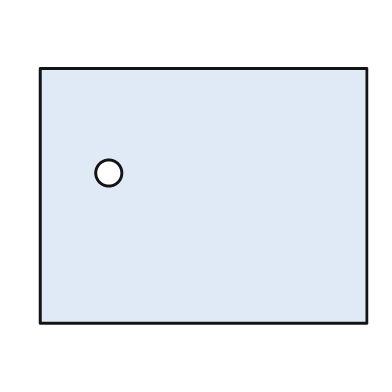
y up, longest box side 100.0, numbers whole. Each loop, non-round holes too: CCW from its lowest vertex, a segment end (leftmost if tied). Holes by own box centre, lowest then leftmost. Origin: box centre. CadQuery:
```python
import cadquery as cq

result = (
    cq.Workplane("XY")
    .moveTo(-50.0, -39.0)
    .lineTo(50.0, -39.0)
    .lineTo(50.0, 39.0)
    .lineTo(-50.0, 39.0)
    .close()
    .moveTo(-29.0, 7.0)
    .circle(4.0)
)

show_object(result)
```